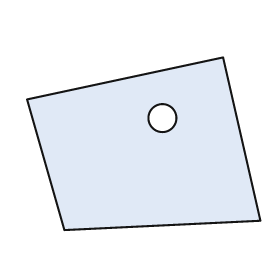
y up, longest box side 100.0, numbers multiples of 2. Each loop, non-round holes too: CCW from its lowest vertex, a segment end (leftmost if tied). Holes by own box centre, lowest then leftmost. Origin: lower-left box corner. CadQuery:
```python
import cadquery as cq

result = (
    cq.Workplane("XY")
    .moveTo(16.0, 0.0)
    .lineTo(100.0, 4.0)
    .lineTo(84.0, 74.0)
    .lineTo(0.0, 56.0)
    .close()
    .moveTo(58.0, 48.0)
    .circle(6.0)
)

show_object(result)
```